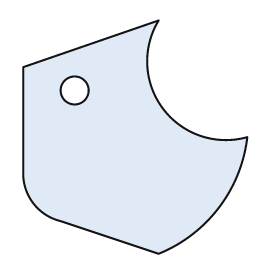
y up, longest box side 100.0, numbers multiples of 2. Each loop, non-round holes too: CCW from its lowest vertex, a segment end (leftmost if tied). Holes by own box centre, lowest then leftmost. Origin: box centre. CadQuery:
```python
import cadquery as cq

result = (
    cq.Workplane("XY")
    .moveTo(10.0, -50.0)
    .threePointArc((36.0, -30.0), (48.0, 0.0))
    .threePointArc((12.0, 12.0), (10.0, 50.0))
    .lineTo(-48.0, 30.0)
    .lineTo(-48.0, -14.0)
    .threePointArc((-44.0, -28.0), (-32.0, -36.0))
    .close()
    .moveTo(-26.0, 20.0)
    .circle(6.0)
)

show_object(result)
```